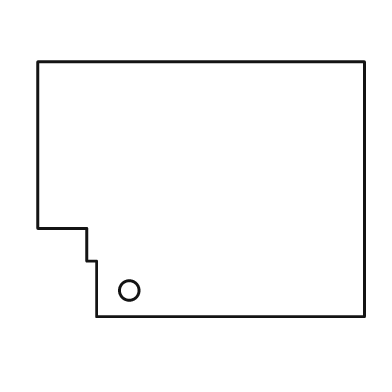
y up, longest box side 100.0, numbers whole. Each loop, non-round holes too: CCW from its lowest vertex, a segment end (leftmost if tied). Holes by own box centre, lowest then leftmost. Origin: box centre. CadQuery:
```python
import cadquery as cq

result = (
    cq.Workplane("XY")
    .moveTo(-32.0, -39.0)
    .lineTo(50.0, -39.0)
    .lineTo(50.0, 39.0)
    .lineTo(-50.0, 39.0)
    .lineTo(-50.0, -12.0)
    .lineTo(-35.0, -12.0)
    .lineTo(-35.0, -22.0)
    .lineTo(-32.0, -22.0)
    .close()
    .moveTo(-22.0, -31.0)
    .circle(3.0)
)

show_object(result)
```